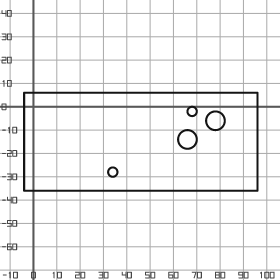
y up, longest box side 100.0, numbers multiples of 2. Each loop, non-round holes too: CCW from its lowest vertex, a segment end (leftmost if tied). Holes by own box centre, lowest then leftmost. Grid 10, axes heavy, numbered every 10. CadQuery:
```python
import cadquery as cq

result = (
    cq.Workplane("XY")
    .moveTo(-4.0, -36.0)
    .lineTo(96.0, -36.0)
    .lineTo(96.0, 6.0)
    .lineTo(-4.0, 6.0)
    .close()
    .moveTo(34.0, -28.0)
    .circle(2.0)
    .moveTo(66.0, -14.0)
    .circle(4.0)
    .moveTo(78.0, -6.0)
    .circle(4.0)
    .moveTo(68.0, -2.0)
    .circle(2.0)
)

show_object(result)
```